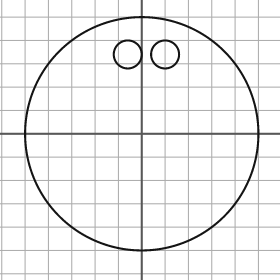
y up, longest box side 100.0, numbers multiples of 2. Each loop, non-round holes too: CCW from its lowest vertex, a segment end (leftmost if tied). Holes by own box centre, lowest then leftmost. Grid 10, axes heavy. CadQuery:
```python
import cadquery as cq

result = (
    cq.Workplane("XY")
    .moveTo(0.0, 0.0)
    .circle(50.0)
    .moveTo(-6.0, 34.0)
    .circle(6.0)
    .moveTo(10.0, 34.0)
    .circle(6.0)
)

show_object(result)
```